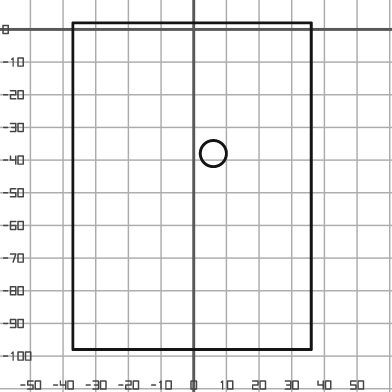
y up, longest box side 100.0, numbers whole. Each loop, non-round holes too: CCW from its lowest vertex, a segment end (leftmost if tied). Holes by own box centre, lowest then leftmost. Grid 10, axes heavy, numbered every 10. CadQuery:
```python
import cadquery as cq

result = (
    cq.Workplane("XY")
    .moveTo(-37.0, -98.0)
    .lineTo(36.0, -98.0)
    .lineTo(36.0, 2.0)
    .lineTo(-37.0, 2.0)
    .close()
    .moveTo(6.0, -38.0)
    .circle(4.0)
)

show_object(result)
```